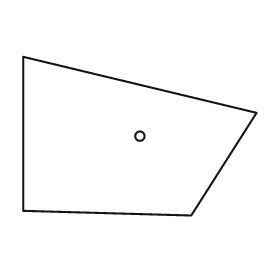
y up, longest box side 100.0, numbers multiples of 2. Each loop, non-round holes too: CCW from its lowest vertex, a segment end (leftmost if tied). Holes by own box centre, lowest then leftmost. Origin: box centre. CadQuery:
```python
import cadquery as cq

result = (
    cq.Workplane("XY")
    .moveTo(22.0, -34.0)
    .lineTo(50.0, 10.0)
    .lineTo(-50.0, 34.0)
    .lineTo(-50.0, -32.0)
    .close()
    .moveTo(0.0, 0.0)
    .circle(2.0)
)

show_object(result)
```